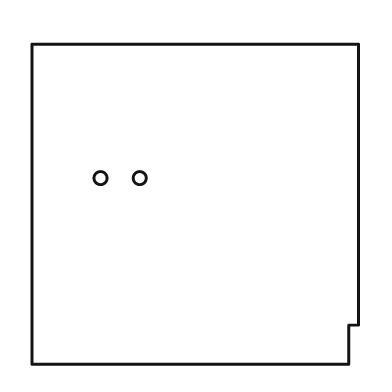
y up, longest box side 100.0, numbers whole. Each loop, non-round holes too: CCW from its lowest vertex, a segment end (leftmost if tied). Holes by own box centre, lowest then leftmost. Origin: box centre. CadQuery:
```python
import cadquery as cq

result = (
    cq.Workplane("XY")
    .moveTo(-50.0, -49.0)
    .lineTo(47.0, -49.0)
    .lineTo(47.0, -37.0)
    .lineTo(50.0, -37.0)
    .lineTo(50.0, 49.0)
    .lineTo(-50.0, 49.0)
    .close()
    .moveTo(-29.0, 8.0)
    .circle(2.0)
    .moveTo(-17.0, 8.0)
    .circle(2.0)
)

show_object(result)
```